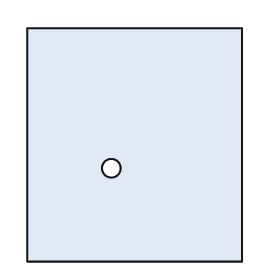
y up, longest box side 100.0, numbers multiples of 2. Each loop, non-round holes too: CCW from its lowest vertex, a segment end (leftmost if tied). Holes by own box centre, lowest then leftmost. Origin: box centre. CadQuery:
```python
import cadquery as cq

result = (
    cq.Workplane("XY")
    .moveTo(-46.0, -50.0)
    .lineTo(46.0, -50.0)
    .lineTo(46.0, 50.0)
    .lineTo(-46.0, 50.0)
    .close()
    .moveTo(-10.0, -10.0)
    .circle(4.0)
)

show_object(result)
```